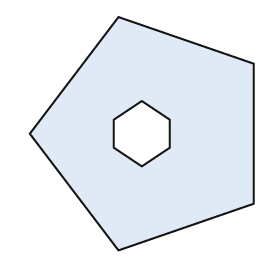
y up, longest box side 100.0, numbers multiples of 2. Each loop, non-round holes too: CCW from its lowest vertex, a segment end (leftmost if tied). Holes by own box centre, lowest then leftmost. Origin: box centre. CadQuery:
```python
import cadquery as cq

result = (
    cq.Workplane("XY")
    .moveTo(-10.0, -50.0)
    .lineTo(48.0, -30.0)
    .lineTo(48.0, 30.0)
    .lineTo(-10.0, 50.0)
    .lineTo(-48.0, 0.0)
    .close()
    .moveTo(0.0, -14.0)
    .lineTo(12.0, -6.0)
    .lineTo(12.0, 6.0)
    .lineTo(0.0, 14.0)
    .lineTo(-12.0, 6.0)
    .lineTo(-12.0, -6.0)
    .close()
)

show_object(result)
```